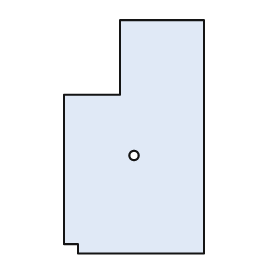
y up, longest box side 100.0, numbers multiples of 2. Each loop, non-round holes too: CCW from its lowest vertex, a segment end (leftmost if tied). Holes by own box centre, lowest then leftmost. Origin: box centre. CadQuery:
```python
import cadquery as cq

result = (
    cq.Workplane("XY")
    .moveTo(-24.0, -50.0)
    .lineTo(30.0, -50.0)
    .lineTo(30.0, 50.0)
    .lineTo(-6.0, 50.0)
    .lineTo(-6.0, 18.0)
    .lineTo(-30.0, 18.0)
    .lineTo(-30.0, -46.0)
    .lineTo(-24.0, -46.0)
    .close()
    .moveTo(0.0, -8.0)
    .circle(2.0)
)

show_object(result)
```